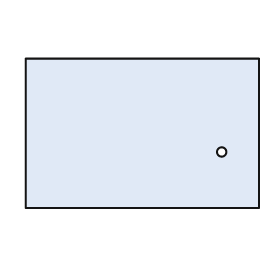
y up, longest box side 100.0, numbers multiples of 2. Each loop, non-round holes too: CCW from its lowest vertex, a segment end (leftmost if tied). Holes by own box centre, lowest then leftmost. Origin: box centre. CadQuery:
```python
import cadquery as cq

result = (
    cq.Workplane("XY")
    .moveTo(-50.0, -32.0)
    .lineTo(50.0, -32.0)
    .lineTo(50.0, 32.0)
    .lineTo(-50.0, 32.0)
    .close()
    .moveTo(34.0, -8.0)
    .circle(2.0)
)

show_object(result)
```